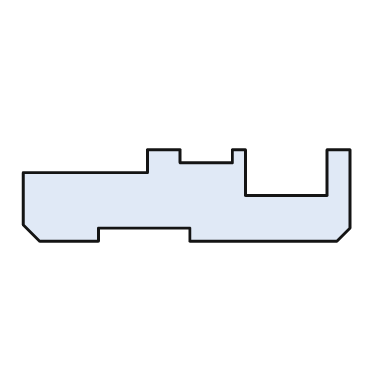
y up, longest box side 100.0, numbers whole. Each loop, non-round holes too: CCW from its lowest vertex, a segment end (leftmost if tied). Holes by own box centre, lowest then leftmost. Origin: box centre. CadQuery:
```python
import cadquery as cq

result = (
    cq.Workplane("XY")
    .moveTo(-45.0, -14.0)
    .lineTo(-27.0, -14.0)
    .lineTo(-27.0, -10.0)
    .lineTo(1.0, -10.0)
    .lineTo(1.0, -14.0)
    .lineTo(46.0, -14.0)
    .lineTo(50.0, -10.0)
    .lineTo(50.0, 14.0)
    .lineTo(43.0, 14.0)
    .lineTo(43.0, 0.0)
    .lineTo(18.0, 0.0)
    .lineTo(18.0, 14.0)
    .lineTo(14.0, 14.0)
    .lineTo(14.0, 10.0)
    .lineTo(-2.0, 10.0)
    .lineTo(-2.0, 14.0)
    .lineTo(-12.0, 14.0)
    .lineTo(-12.0, 7.0)
    .lineTo(-50.0, 7.0)
    .lineTo(-50.0, -9.0)
    .close()
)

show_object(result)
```